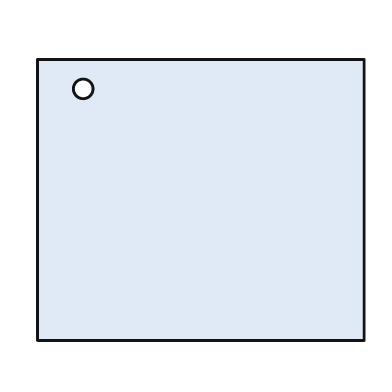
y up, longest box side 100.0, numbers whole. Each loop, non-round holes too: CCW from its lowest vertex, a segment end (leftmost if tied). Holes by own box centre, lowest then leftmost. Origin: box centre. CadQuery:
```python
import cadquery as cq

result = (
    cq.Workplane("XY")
    .moveTo(-50.0, -43.0)
    .lineTo(50.0, -43.0)
    .lineTo(50.0, 43.0)
    .lineTo(-50.0, 43.0)
    .close()
    .moveTo(-36.0, 34.0)
    .circle(3.0)
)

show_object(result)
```